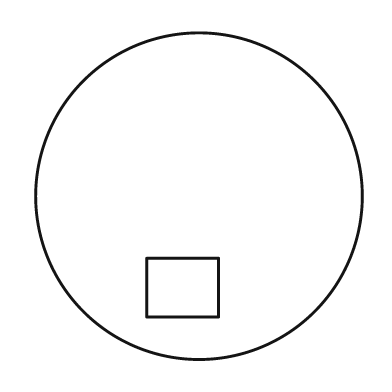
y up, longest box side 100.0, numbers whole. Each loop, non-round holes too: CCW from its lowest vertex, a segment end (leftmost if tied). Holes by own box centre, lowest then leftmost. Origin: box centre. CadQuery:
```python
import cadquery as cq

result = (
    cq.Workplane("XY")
    .moveTo(0.0, 0.0)
    .circle(50.0)
    .moveTo(-16.0, -37.0)
    .lineTo(6.0, -37.0)
    .lineTo(6.0, -19.0)
    .lineTo(-16.0, -19.0)
    .close()
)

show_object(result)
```